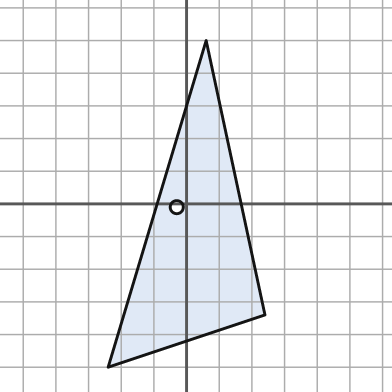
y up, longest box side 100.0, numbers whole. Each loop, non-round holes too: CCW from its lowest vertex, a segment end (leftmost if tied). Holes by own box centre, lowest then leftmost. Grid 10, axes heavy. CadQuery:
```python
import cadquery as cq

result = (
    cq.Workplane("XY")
    .moveTo(-24.0, -50.0)
    .lineTo(24.0, -34.0)
    .lineTo(6.0, 50.0)
    .close()
    .moveTo(-3.0, -1.0)
    .circle(2.0)
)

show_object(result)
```